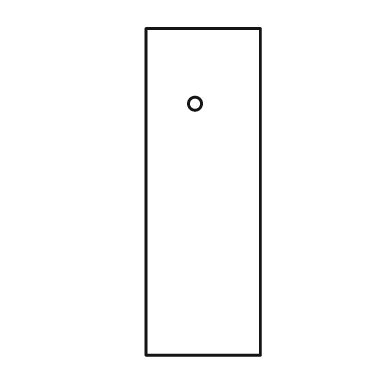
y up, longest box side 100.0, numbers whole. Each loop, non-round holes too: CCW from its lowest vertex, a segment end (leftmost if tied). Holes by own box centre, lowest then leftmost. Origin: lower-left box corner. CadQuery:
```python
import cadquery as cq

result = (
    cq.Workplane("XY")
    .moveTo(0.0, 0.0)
    .lineTo(35.0, 0.0)
    .lineTo(35.0, 100.0)
    .lineTo(0.0, 100.0)
    .close()
    .moveTo(15.0, 77.0)
    .circle(2.0)
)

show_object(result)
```